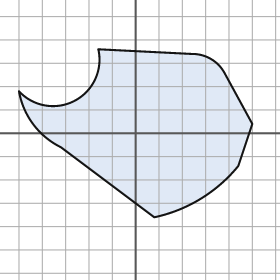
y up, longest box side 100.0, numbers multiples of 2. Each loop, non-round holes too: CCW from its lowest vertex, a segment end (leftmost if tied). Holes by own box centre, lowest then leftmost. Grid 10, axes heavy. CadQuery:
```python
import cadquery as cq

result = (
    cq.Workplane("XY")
    .moveTo(8.0, -36.0)
    .threePointArc((28.0, -28.0), (44.0, -14.0))
    .lineTo(50.0, 4.0)
    .lineTo(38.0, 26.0)
    .threePointArc((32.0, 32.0), (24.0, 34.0))
    .lineTo(-16.0, 36.0)
    .threePointArc((-26.0, 14.0), (-50.0, 18.0))
    .threePointArc((-44.0, 4.0), (-32.0, -6.0))
    .close()
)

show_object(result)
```